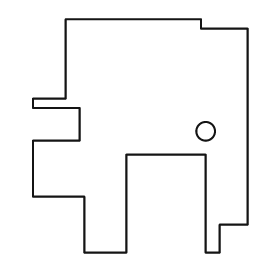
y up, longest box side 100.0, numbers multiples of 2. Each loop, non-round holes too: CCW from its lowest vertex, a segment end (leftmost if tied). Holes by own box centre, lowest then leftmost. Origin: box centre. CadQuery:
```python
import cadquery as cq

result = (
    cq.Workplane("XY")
    .moveTo(-24.0, -50.0)
    .lineTo(-6.0, -50.0)
    .lineTo(-6.0, -8.0)
    .lineTo(28.0, -8.0)
    .lineTo(28.0, -50.0)
    .lineTo(34.0, -50.0)
    .lineTo(34.0, -38.0)
    .lineTo(46.0, -38.0)
    .lineTo(46.0, 46.0)
    .lineTo(26.0, 46.0)
    .lineTo(26.0, 50.0)
    .lineTo(-32.0, 50.0)
    .lineTo(-32.0, 16.0)
    .lineTo(-46.0, 16.0)
    .lineTo(-46.0, 12.0)
    .lineTo(-26.0, 12.0)
    .lineTo(-26.0, -2.0)
    .lineTo(-46.0, -2.0)
    .lineTo(-46.0, -26.0)
    .lineTo(-24.0, -26.0)
    .close()
    .moveTo(28.0, 2.0)
    .circle(4.0)
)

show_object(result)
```